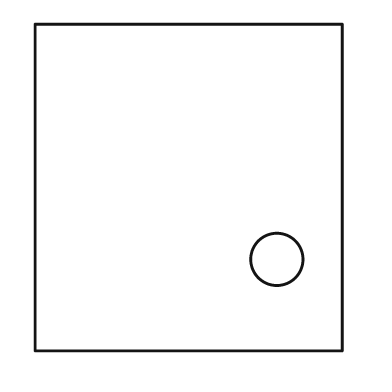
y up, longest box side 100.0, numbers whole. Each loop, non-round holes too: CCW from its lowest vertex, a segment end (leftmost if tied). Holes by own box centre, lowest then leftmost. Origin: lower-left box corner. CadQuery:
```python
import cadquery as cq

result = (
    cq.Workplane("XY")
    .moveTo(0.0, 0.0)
    .lineTo(94.0, 0.0)
    .lineTo(94.0, 100.0)
    .lineTo(0.0, 100.0)
    .close()
    .moveTo(74.0, 28.0)
    .circle(8.0)
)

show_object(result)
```